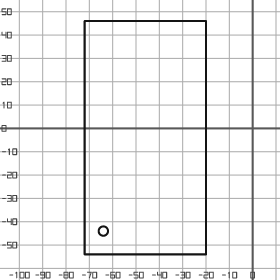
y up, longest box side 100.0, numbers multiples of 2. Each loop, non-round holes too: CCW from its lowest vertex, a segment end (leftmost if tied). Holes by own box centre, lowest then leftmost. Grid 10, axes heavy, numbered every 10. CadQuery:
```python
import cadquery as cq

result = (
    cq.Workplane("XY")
    .moveTo(-72.0, -54.0)
    .lineTo(-20.0, -54.0)
    .lineTo(-20.0, 46.0)
    .lineTo(-72.0, 46.0)
    .close()
    .moveTo(-64.0, -44.0)
    .circle(2.0)
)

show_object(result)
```